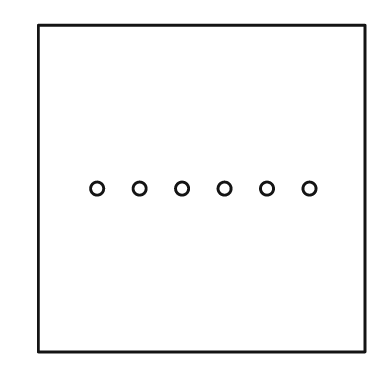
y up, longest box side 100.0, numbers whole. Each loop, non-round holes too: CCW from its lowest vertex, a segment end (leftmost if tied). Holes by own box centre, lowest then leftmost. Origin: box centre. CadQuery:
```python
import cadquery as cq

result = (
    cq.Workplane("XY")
    .moveTo(-50.0, -50.0)
    .lineTo(50.0, -50.0)
    .lineTo(50.0, 50.0)
    .lineTo(-50.0, 50.0)
    .close()
    .moveTo(-32.0, 0.0)
    .circle(2.0)
    .moveTo(-19.0, 0.0)
    .circle(2.0)
    .moveTo(-6.0, 0.0)
    .circle(2.0)
    .moveTo(7.0, 0.0)
    .circle(2.0)
    .moveTo(20.0, 0.0)
    .circle(2.0)
    .moveTo(33.0, 0.0)
    .circle(2.0)
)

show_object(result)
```